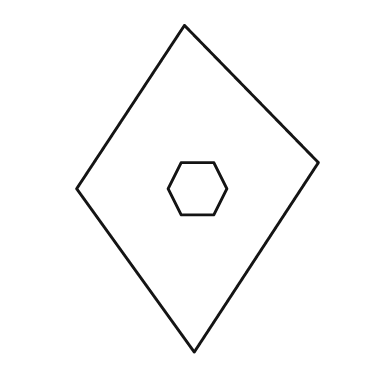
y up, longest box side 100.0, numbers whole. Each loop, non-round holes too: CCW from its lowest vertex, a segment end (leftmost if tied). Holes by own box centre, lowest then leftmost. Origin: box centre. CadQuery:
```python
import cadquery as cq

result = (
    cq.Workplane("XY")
    .moveTo(-1.0, -50.0)
    .lineTo(37.0, 8.0)
    .lineTo(-4.0, 50.0)
    .lineTo(-37.0, 0.0)
    .close()
    .moveTo(-5.0, -8.0)
    .lineTo(5.0, -8.0)
    .lineTo(9.0, 0.0)
    .lineTo(5.0, 8.0)
    .lineTo(-5.0, 8.0)
    .lineTo(-9.0, 0.0)
    .close()
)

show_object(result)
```